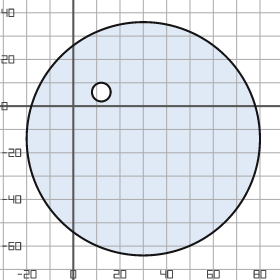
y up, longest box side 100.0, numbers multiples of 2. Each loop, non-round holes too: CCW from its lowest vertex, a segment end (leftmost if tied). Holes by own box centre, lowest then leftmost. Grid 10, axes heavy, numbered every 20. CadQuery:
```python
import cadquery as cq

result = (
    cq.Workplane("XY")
    .moveTo(30.0, -14.0)
    .circle(50.0)
    .moveTo(12.0, 6.0)
    .circle(4.0)
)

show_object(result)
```